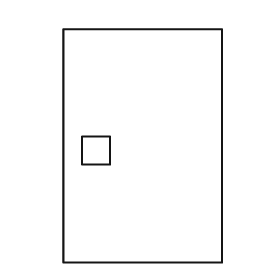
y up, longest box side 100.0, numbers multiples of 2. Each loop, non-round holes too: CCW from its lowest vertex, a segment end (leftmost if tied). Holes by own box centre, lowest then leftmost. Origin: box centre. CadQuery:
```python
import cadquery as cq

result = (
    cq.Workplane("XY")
    .moveTo(-34.0, -50.0)
    .lineTo(34.0, -50.0)
    .lineTo(34.0, 50.0)
    .lineTo(-34.0, 50.0)
    .close()
    .moveTo(-26.0, -8.0)
    .lineTo(-14.0, -8.0)
    .lineTo(-14.0, 4.0)
    .lineTo(-26.0, 4.0)
    .close()
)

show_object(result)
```